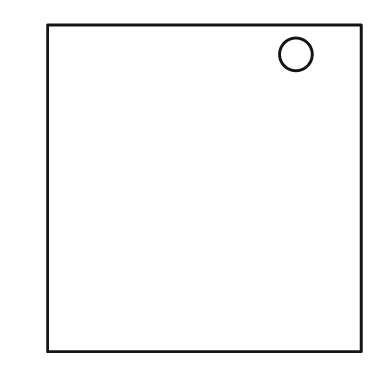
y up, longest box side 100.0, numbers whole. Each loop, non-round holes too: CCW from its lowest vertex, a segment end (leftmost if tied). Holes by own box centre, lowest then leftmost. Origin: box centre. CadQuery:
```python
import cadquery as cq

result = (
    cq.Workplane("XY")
    .moveTo(-48.0, -50.0)
    .lineTo(48.0, -50.0)
    .lineTo(48.0, 50.0)
    .lineTo(-48.0, 50.0)
    .close()
    .moveTo(28.0, 41.0)
    .circle(5.0)
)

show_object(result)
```